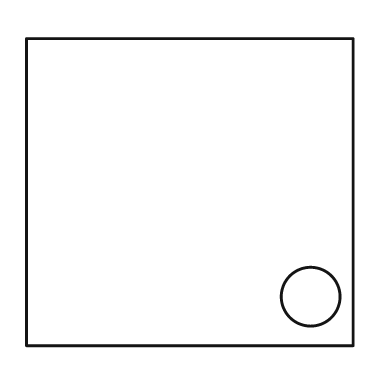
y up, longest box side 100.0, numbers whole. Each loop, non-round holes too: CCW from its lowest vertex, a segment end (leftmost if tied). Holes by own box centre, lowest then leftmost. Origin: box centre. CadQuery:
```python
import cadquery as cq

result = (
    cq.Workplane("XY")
    .moveTo(-50.0, -47.0)
    .lineTo(50.0, -47.0)
    .lineTo(50.0, 47.0)
    .lineTo(-50.0, 47.0)
    .close()
    .moveTo(37.0, -32.0)
    .circle(9.0)
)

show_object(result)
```